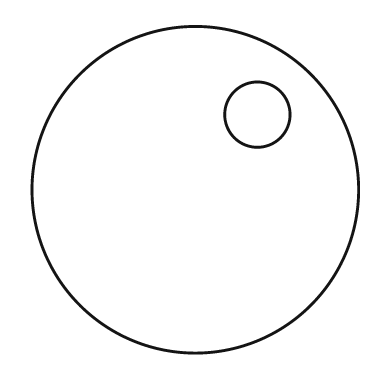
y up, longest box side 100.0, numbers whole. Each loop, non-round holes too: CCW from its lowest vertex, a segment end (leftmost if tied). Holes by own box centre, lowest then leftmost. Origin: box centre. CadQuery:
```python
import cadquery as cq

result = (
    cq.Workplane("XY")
    .moveTo(0.0, 0.0)
    .circle(50.0)
    .moveTo(19.0, 23.0)
    .circle(10.0)
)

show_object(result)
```